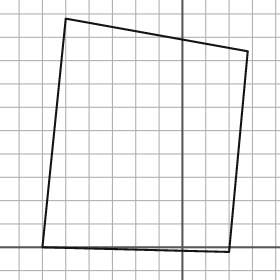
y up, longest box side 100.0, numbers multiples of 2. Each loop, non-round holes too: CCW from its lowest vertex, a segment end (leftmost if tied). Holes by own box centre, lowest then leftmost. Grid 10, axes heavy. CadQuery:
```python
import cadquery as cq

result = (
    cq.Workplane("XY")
    .moveTo(20.0, -2.0)
    .lineTo(28.0, 84.0)
    .lineTo(-50.0, 98.0)
    .lineTo(-60.0, 0.0)
    .close()
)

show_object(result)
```